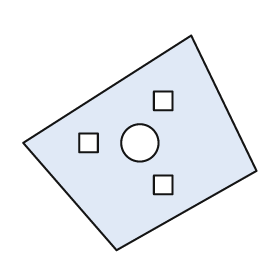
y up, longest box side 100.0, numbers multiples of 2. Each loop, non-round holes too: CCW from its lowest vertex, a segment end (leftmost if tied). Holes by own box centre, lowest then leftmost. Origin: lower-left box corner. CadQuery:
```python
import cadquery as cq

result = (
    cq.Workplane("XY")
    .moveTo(40.0, 0.0)
    .lineTo(100.0, 34.0)
    .lineTo(72.0, 92.0)
    .lineTo(0.0, 46.0)
    .close()
    .moveTo(56.0, 24.0)
    .lineTo(64.0, 24.0)
    .lineTo(64.0, 32.0)
    .lineTo(56.0, 32.0)
    .close()
    .moveTo(24.0, 42.0)
    .lineTo(32.0, 42.0)
    .lineTo(32.0, 50.0)
    .lineTo(24.0, 50.0)
    .close()
    .moveTo(50.0, 46.0)
    .circle(8.0)
    .moveTo(56.0, 60.0)
    .lineTo(64.0, 60.0)
    .lineTo(64.0, 68.0)
    .lineTo(56.0, 68.0)
    .close()
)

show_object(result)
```